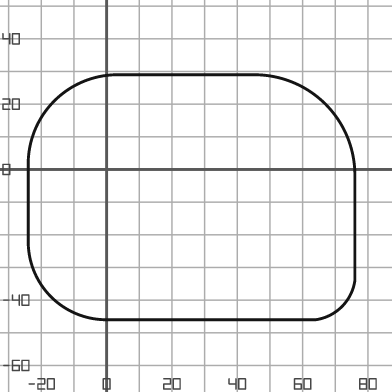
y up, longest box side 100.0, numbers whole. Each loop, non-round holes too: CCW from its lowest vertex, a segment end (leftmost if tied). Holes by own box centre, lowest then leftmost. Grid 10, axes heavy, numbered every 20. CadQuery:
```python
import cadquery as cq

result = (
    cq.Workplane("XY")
    .moveTo(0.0, -46.0)
    .lineTo(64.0, -46.0)
    .threePointArc((72.0, -42.0), (76.0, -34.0))
    .lineTo(76.0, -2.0)
    .threePointArc((67.0, 20.0), (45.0, 29.0))
    .lineTo(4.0, 29.0)
    .threePointArc((-16.0, 21.0), (-24.0, 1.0))
    .lineTo(-24.0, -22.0)
    .threePointArc((-17.0, -39.0), (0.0, -46.0))
    .close()
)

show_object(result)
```